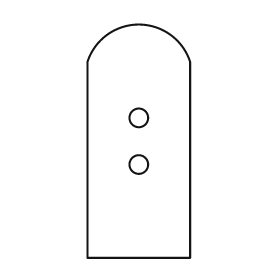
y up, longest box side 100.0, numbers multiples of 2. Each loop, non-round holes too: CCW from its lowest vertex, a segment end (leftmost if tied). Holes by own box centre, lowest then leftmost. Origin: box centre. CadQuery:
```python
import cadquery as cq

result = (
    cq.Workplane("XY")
    .moveTo(-22.0, -50.0)
    .lineTo(22.0, -50.0)
    .lineTo(22.0, 34.0)
    .threePointArc((0.0, 50.0), (-22.0, 34.0))
    .close()
    .moveTo(0.0, -10.0)
    .circle(4.0)
    .moveTo(0.0, 10.0)
    .circle(4.0)
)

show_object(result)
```